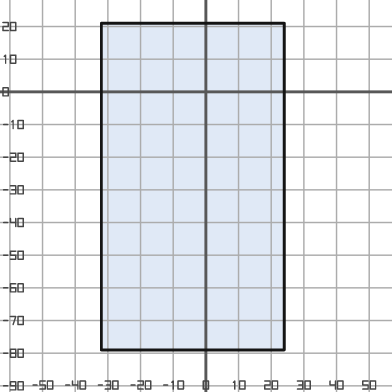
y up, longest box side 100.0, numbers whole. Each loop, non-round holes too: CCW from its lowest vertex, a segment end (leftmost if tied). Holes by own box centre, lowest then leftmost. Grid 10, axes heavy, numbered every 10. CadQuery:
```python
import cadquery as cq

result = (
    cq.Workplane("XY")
    .moveTo(-32.0, -79.0)
    .lineTo(24.0, -79.0)
    .lineTo(24.0, 21.0)
    .lineTo(-32.0, 21.0)
    .close()
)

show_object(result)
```